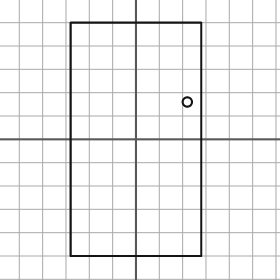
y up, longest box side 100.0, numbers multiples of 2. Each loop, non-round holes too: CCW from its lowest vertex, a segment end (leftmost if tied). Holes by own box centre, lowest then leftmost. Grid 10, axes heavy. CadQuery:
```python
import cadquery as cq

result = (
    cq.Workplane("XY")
    .moveTo(-28.0, -50.0)
    .lineTo(28.0, -50.0)
    .lineTo(28.0, 50.0)
    .lineTo(-28.0, 50.0)
    .close()
    .moveTo(22.0, 16.0)
    .circle(2.0)
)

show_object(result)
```